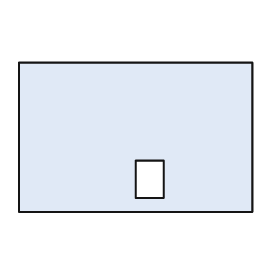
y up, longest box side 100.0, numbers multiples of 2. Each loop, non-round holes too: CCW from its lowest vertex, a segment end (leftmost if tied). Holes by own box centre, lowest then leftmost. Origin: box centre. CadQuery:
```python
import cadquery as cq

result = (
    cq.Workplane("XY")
    .moveTo(-50.0, -32.0)
    .lineTo(50.0, -32.0)
    .lineTo(50.0, 32.0)
    .lineTo(-50.0, 32.0)
    .close()
    .moveTo(0.0, -26.0)
    .lineTo(12.0, -26.0)
    .lineTo(12.0, -10.0)
    .lineTo(0.0, -10.0)
    .close()
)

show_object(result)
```